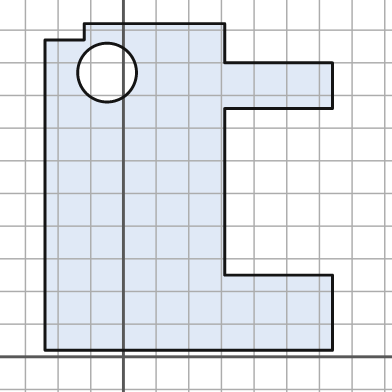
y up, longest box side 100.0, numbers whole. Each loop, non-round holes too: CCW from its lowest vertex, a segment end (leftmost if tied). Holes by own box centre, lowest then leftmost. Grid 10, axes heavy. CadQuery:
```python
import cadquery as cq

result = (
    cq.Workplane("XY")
    .moveTo(-24.0, 2.0)
    .lineTo(64.0, 2.0)
    .lineTo(64.0, 25.0)
    .lineTo(31.0, 25.0)
    .lineTo(31.0, 76.0)
    .lineTo(64.0, 76.0)
    .lineTo(64.0, 90.0)
    .lineTo(31.0, 90.0)
    .lineTo(31.0, 102.0)
    .lineTo(-12.0, 102.0)
    .lineTo(-12.0, 97.0)
    .lineTo(-24.0, 97.0)
    .close()
    .moveTo(-5.0, 87.0)
    .circle(9.0)
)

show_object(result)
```